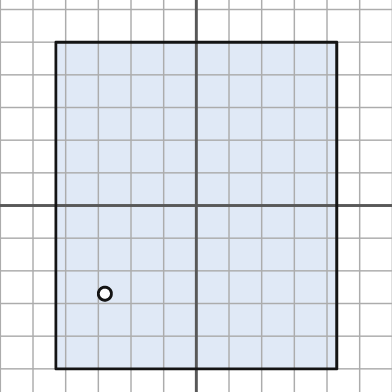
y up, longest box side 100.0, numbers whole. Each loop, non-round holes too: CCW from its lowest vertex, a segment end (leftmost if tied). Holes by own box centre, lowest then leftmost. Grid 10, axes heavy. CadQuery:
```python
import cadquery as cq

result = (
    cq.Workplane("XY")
    .moveTo(-43.0, -50.0)
    .lineTo(43.0, -50.0)
    .lineTo(43.0, 50.0)
    .lineTo(-43.0, 50.0)
    .close()
    .moveTo(-28.0, -27.0)
    .circle(2.0)
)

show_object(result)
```